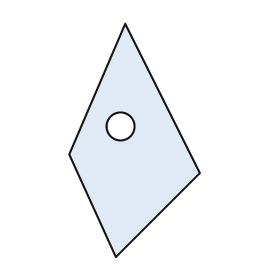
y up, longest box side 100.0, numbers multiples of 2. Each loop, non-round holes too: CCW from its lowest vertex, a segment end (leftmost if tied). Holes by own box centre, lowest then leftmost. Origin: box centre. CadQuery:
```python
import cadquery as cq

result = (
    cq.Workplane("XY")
    .moveTo(-8.0, -50.0)
    .lineTo(28.0, -14.0)
    .lineTo(-4.0, 50.0)
    .lineTo(-28.0, -6.0)
    .close()
    .moveTo(-6.0, 6.0)
    .circle(6.0)
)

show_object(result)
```